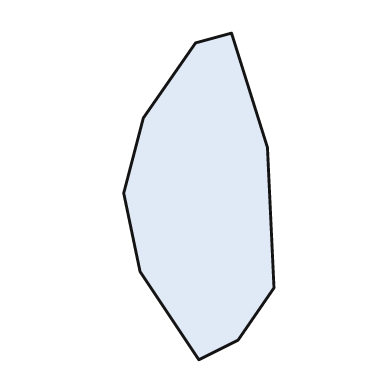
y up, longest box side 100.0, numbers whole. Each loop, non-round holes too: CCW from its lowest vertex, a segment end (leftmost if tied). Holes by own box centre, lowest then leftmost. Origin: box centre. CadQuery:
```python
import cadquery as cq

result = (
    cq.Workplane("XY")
    .moveTo(0.0, -50.0)
    .lineTo(12.0, -44.0)
    .lineTo(23.0, -28.0)
    .lineTo(21.0, 15.0)
    .lineTo(10.0, 50.0)
    .lineTo(-1.0, 47.0)
    .lineTo(-17.0, 24.0)
    .lineTo(-23.0, 1.0)
    .lineTo(-18.0, -23.0)
    .close()
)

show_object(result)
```